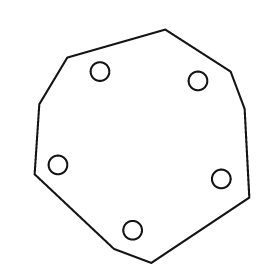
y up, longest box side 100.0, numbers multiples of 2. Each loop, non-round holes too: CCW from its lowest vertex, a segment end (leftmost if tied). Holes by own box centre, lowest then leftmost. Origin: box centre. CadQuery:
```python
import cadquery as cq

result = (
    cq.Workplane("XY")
    .moveTo(4.0, -50.0)
    .lineTo(46.0, -22.0)
    .lineTo(44.0, 16.0)
    .lineTo(38.0, 32.0)
    .lineTo(10.0, 50.0)
    .lineTo(-32.0, 38.0)
    .lineTo(-44.0, 18.0)
    .lineTo(-46.0, -12.0)
    .lineTo(-12.0, -44.0)
    .close()
    .moveTo(-4.0, -36.0)
    .circle(4.0)
    .moveTo(34.0, -14.0)
    .circle(4.0)
    .moveTo(-36.0, -8.0)
    .circle(4.0)
    .moveTo(24.0, 28.0)
    .circle(4.0)
    .moveTo(-18.0, 32.0)
    .circle(4.0)
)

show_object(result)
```